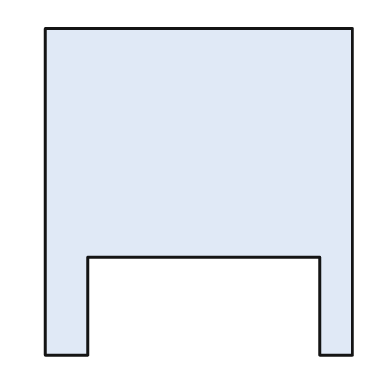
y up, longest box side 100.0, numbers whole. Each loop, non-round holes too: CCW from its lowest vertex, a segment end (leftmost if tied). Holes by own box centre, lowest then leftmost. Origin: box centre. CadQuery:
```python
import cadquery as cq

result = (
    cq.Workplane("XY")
    .moveTo(-47.0, -50.0)
    .lineTo(-34.0, -50.0)
    .lineTo(-34.0, -20.0)
    .lineTo(37.0, -20.0)
    .lineTo(37.0, -50.0)
    .lineTo(47.0, -50.0)
    .lineTo(47.0, 50.0)
    .lineTo(-47.0, 50.0)
    .close()
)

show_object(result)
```